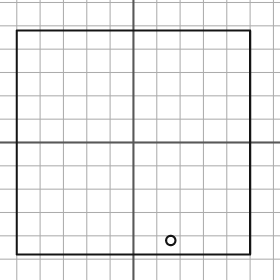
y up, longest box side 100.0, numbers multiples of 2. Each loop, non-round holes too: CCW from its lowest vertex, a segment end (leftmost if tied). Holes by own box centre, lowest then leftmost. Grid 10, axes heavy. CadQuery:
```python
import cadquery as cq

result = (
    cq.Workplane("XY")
    .moveTo(-50.0, -48.0)
    .lineTo(50.0, -48.0)
    .lineTo(50.0, 48.0)
    .lineTo(-50.0, 48.0)
    .close()
    .moveTo(16.0, -42.0)
    .circle(2.0)
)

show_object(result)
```